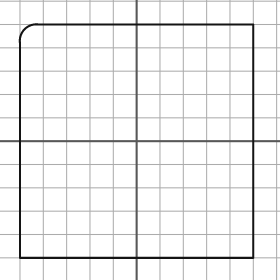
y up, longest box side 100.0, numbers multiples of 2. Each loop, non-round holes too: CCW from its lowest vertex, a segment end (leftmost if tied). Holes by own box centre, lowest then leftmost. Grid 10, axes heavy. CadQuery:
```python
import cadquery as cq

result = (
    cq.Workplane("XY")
    .moveTo(-50.0, -50.0)
    .lineTo(50.0, -50.0)
    .lineTo(50.0, 50.0)
    .lineTo(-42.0, 50.0)
    .threePointArc((-48.0, 48.0), (-50.0, 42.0))
    .close()
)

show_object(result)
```